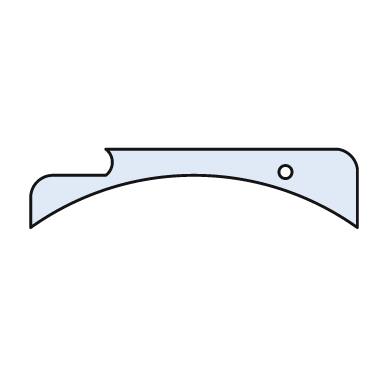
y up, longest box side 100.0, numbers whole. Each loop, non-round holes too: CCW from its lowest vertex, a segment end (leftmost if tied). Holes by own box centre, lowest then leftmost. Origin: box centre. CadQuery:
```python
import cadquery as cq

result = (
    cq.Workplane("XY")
    .moveTo(-50.0, -12.0)
    .threePointArc((0.0, 4.0), (50.0, -12.0))
    .lineTo(50.0, 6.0)
    .threePointArc((48.0, 10.0), (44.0, 12.0))
    .lineTo(-27.0, 12.0)
    .threePointArc((-25.0, 8.0), (-27.0, 4.0))
    .lineTo(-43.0, 4.0)
    .threePointArc((-48.0, 2.0), (-50.0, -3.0))
    .close()
    .moveTo(28.0, 5.0)
    .circle(2.0)
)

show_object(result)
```